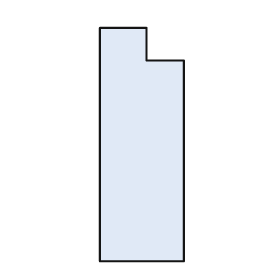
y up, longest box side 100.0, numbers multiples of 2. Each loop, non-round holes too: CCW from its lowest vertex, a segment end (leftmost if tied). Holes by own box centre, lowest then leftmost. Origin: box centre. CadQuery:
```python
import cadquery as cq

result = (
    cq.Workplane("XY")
    .moveTo(-18.0, -50.0)
    .lineTo(18.0, -50.0)
    .lineTo(18.0, 36.0)
    .lineTo(2.0, 36.0)
    .lineTo(2.0, 50.0)
    .lineTo(-18.0, 50.0)
    .close()
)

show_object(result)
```